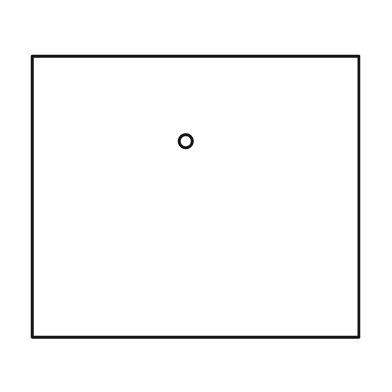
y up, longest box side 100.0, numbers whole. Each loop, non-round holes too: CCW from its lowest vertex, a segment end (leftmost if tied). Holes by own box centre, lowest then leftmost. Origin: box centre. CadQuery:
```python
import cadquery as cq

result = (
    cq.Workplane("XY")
    .moveTo(-50.0, -43.0)
    .lineTo(50.0, -43.0)
    .lineTo(50.0, 43.0)
    .lineTo(-50.0, 43.0)
    .close()
    .moveTo(-3.0, 17.0)
    .circle(2.0)
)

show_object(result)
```